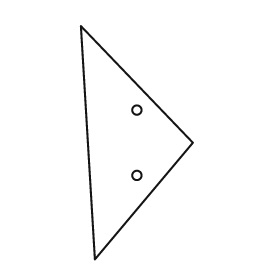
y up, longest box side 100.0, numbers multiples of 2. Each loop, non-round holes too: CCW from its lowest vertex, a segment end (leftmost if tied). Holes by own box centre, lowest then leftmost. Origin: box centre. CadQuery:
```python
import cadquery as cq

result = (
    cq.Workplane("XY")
    .moveTo(-18.0, -50.0)
    .lineTo(24.0, 0.0)
    .lineTo(-24.0, 50.0)
    .close()
    .moveTo(0.0, -14.0)
    .circle(2.0)
    .moveTo(0.0, 14.0)
    .circle(2.0)
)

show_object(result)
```